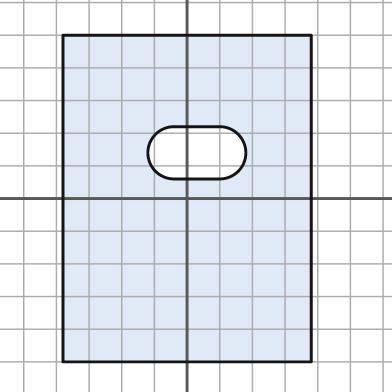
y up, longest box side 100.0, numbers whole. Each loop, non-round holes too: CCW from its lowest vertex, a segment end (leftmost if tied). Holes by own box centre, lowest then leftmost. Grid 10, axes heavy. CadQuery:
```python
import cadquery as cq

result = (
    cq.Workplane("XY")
    .moveTo(-38.0, -50.0)
    .lineTo(38.0, -50.0)
    .lineTo(38.0, 50.0)
    .lineTo(-38.0, 50.0)
    .close()
    .moveTo(-4.0, 6.0)
    .lineTo(10.0, 6.0)
    .threePointArc((18.0, 14.0), (10.0, 22.0))
    .lineTo(-4.0, 22.0)
    .threePointArc((-12.0, 14.0), (-4.0, 6.0))
    .close()
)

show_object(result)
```